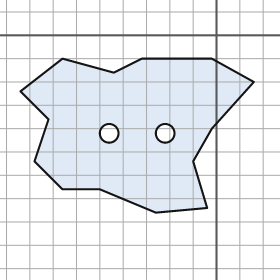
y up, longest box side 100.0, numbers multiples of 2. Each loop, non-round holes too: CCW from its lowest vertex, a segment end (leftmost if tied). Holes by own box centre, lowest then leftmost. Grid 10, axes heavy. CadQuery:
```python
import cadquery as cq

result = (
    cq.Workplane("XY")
    .moveTo(-26.0, -76.0)
    .lineTo(-4.0, -74.0)
    .lineTo(-10.0, -54.0)
    .lineTo(-2.0, -40.0)
    .lineTo(16.0, -20.0)
    .lineTo(-2.0, -10.0)
    .lineTo(-32.0, -10.0)
    .lineTo(-44.0, -16.0)
    .lineTo(-66.0, -10.0)
    .lineTo(-84.0, -24.0)
    .lineTo(-72.0, -36.0)
    .lineTo(-78.0, -54.0)
    .lineTo(-66.0, -66.0)
    .lineTo(-50.0, -66.0)
    .close()
    .moveTo(-46.0, -42.0)
    .circle(4.0)
    .moveTo(-22.0, -42.0)
    .circle(4.0)
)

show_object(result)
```